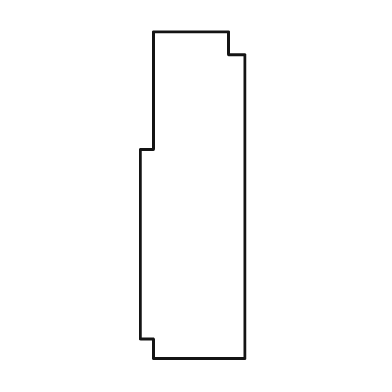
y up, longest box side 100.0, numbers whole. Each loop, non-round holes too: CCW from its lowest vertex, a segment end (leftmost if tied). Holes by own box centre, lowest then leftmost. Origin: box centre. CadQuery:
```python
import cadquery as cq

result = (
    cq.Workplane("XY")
    .moveTo(-12.0, -50.0)
    .lineTo(16.0, -50.0)
    .lineTo(16.0, 43.0)
    .lineTo(11.0, 43.0)
    .lineTo(11.0, 50.0)
    .lineTo(-12.0, 50.0)
    .lineTo(-12.0, 14.0)
    .lineTo(-16.0, 14.0)
    .lineTo(-16.0, -44.0)
    .lineTo(-12.0, -44.0)
    .close()
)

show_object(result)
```